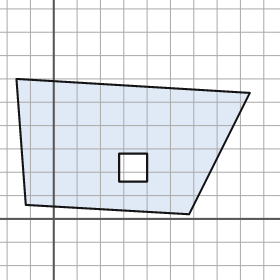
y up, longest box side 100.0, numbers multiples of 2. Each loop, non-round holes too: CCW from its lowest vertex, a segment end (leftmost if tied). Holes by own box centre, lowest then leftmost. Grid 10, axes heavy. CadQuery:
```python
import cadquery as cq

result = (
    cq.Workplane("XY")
    .moveTo(58.0, 2.0)
    .lineTo(84.0, 54.0)
    .lineTo(-16.0, 60.0)
    .lineTo(-12.0, 6.0)
    .close()
    .moveTo(28.0, 16.0)
    .lineTo(40.0, 16.0)
    .lineTo(40.0, 28.0)
    .lineTo(28.0, 28.0)
    .close()
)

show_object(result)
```